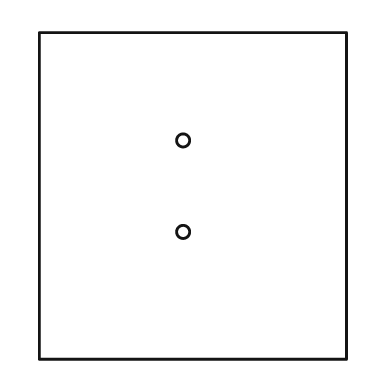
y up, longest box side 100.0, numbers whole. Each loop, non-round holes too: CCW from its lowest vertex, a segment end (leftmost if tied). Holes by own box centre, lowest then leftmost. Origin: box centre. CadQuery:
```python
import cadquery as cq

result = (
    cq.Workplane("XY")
    .moveTo(-47.0, -50.0)
    .lineTo(47.0, -50.0)
    .lineTo(47.0, 50.0)
    .lineTo(-47.0, 50.0)
    .close()
    .moveTo(-3.0, -11.0)
    .circle(2.0)
    .moveTo(-3.0, 17.0)
    .circle(2.0)
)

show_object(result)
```